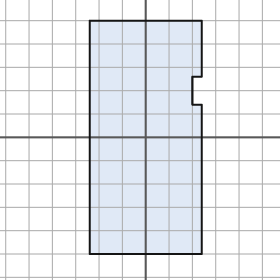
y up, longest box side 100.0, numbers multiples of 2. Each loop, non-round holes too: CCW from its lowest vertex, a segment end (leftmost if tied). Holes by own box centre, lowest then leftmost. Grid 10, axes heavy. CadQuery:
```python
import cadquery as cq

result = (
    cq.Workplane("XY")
    .moveTo(-24.0, -50.0)
    .lineTo(24.0, -50.0)
    .lineTo(24.0, 14.0)
    .lineTo(20.0, 14.0)
    .lineTo(20.0, 26.0)
    .lineTo(24.0, 26.0)
    .lineTo(24.0, 50.0)
    .lineTo(-24.0, 50.0)
    .close()
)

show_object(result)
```